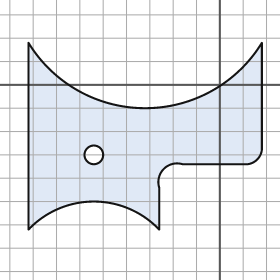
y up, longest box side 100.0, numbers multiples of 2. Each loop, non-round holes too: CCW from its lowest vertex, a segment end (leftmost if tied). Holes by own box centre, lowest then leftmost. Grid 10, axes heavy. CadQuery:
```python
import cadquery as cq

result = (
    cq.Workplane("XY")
    .moveTo(-82.0, -62.0)
    .threePointArc((-54.0, -50.0), (-26.0, -62.0))
    .lineTo(-26.0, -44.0)
    .threePointArc((-24.0, -36.0), (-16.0, -34.0))
    .lineTo(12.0, -34.0)
    .threePointArc((16.0, -32.0), (18.0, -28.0))
    .lineTo(18.0, 18.0)
    .threePointArc((-32.0, -10.0), (-82.0, 18.0))
    .close()
    .moveTo(-54.0, -30.0)
    .circle(4.0)
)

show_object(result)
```